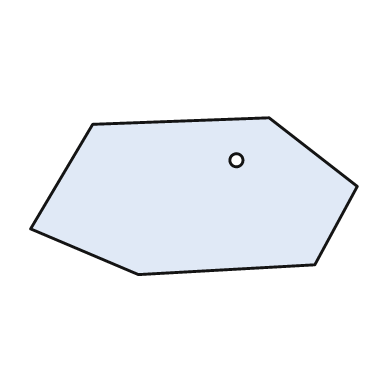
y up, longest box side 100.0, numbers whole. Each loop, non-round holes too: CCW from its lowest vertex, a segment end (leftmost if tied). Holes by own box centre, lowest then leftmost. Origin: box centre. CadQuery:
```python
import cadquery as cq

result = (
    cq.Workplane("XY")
    .moveTo(-17.0, -24.0)
    .lineTo(37.0, -21.0)
    .lineTo(50.0, 3.0)
    .lineTo(23.0, 24.0)
    .lineTo(-31.0, 22.0)
    .lineTo(-50.0, -10.0)
    .close()
    .moveTo(13.0, 11.0)
    .circle(2.0)
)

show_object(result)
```